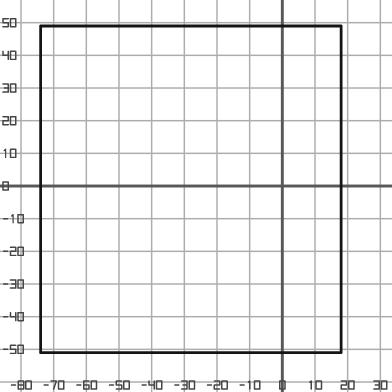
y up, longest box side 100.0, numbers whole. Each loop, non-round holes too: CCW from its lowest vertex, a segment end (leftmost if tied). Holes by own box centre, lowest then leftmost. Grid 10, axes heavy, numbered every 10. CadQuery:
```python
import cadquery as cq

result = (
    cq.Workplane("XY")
    .moveTo(-74.0, -51.0)
    .lineTo(18.0, -51.0)
    .lineTo(18.0, 49.0)
    .lineTo(-74.0, 49.0)
    .close()
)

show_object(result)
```